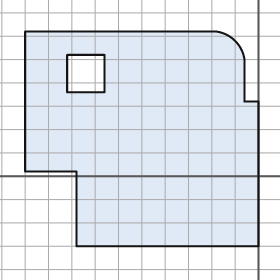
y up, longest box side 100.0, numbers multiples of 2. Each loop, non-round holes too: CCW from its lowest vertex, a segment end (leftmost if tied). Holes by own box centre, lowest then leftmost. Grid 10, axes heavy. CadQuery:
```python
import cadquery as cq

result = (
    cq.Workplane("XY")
    .moveTo(-78.0, -30.0)
    .lineTo(0.0, -30.0)
    .lineTo(0.0, 32.0)
    .lineTo(-6.0, 32.0)
    .lineTo(-6.0, 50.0)
    .threePointArc((-10.0, 58.0), (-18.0, 62.0))
    .lineTo(-100.0, 62.0)
    .lineTo(-100.0, 2.0)
    .lineTo(-78.0, 2.0)
    .close()
    .moveTo(-82.0, 36.0)
    .lineTo(-66.0, 36.0)
    .lineTo(-66.0, 52.0)
    .lineTo(-82.0, 52.0)
    .close()
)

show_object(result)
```